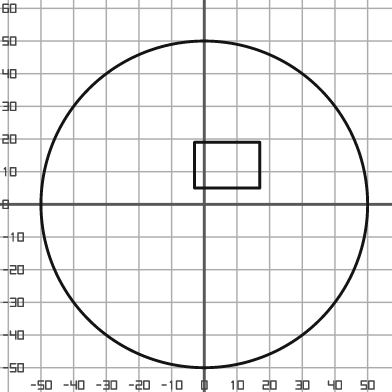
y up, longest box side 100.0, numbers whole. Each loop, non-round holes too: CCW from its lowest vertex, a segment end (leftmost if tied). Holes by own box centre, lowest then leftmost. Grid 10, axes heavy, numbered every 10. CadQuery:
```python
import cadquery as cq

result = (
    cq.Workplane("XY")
    .moveTo(0.0, 0.0)
    .circle(50.0)
    .moveTo(-3.0, 5.0)
    .lineTo(17.0, 5.0)
    .lineTo(17.0, 19.0)
    .lineTo(-3.0, 19.0)
    .close()
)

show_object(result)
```